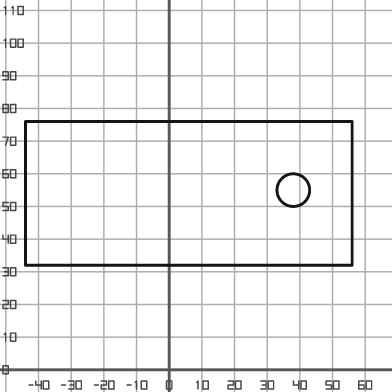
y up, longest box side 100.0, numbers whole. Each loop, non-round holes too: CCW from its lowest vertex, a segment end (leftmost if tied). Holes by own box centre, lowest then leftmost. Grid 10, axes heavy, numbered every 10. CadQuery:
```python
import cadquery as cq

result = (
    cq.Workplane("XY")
    .moveTo(-44.0, 32.0)
    .lineTo(56.0, 32.0)
    .lineTo(56.0, 76.0)
    .lineTo(-44.0, 76.0)
    .close()
    .moveTo(38.0, 55.0)
    .circle(5.0)
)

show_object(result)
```